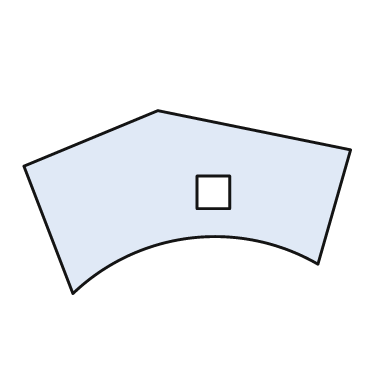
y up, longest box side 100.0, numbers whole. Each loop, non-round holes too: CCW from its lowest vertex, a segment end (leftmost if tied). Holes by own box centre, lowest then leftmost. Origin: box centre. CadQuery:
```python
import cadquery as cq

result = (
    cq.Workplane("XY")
    .moveTo(-35.0, -28.0)
    .threePointArc((1.0, -11.0), (40.0, -19.0))
    .lineTo(50.0, 16.0)
    .lineTo(-9.0, 28.0)
    .lineTo(-50.0, 11.0)
    .close()
    .moveTo(3.0, -2.0)
    .lineTo(13.0, -2.0)
    .lineTo(13.0, 8.0)
    .lineTo(3.0, 8.0)
    .close()
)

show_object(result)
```